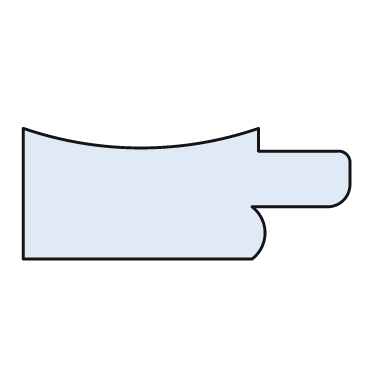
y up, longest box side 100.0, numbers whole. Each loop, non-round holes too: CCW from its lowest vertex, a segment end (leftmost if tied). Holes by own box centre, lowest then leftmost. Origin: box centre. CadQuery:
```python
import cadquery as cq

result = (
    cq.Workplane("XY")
    .moveTo(-50.0, -20.0)
    .lineTo(20.0, -20.0)
    .threePointArc((24.0, -12.0), (20.0, -4.0))
    .lineTo(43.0, -4.0)
    .threePointArc((48.0, -2.0), (50.0, 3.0))
    .lineTo(50.0, 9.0)
    .threePointArc((49.0, 12.0), (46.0, 13.0))
    .lineTo(22.0, 13.0)
    .lineTo(22.0, 20.0)
    .threePointArc((-14.0, 14.0), (-50.0, 20.0))
    .close()
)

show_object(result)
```